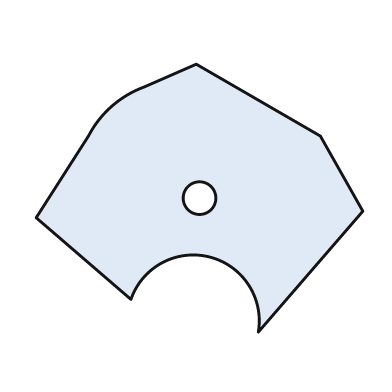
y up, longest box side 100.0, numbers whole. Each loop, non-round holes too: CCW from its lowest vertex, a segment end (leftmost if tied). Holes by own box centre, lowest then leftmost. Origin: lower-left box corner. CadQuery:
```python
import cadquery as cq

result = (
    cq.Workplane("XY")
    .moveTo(68.0, 0.0)
    .lineTo(100.0, 37.0)
    .lineTo(87.0, 60.0)
    .lineTo(49.0, 82.0)
    .lineTo(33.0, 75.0)
    .threePointArc((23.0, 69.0), (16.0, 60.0))
    .lineTo(0.0, 35.0)
    .lineTo(29.0, 10.0)
    .threePointArc((53.0, 23.0), (68.0, 0.0))
    .close()
    .moveTo(50.0, 41.0)
    .circle(5.0)
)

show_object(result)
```